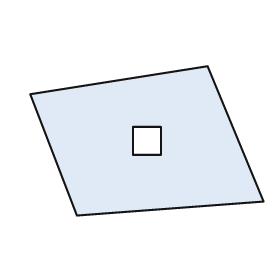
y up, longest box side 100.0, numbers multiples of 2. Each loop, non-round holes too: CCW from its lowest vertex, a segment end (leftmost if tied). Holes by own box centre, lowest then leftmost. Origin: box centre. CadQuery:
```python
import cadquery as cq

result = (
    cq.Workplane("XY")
    .moveTo(-30.0, -32.0)
    .lineTo(50.0, -26.0)
    .lineTo(26.0, 32.0)
    .lineTo(-50.0, 20.0)
    .close()
    .moveTo(-6.0, -6.0)
    .lineTo(6.0, -6.0)
    .lineTo(6.0, 6.0)
    .lineTo(-6.0, 6.0)
    .close()
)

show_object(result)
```